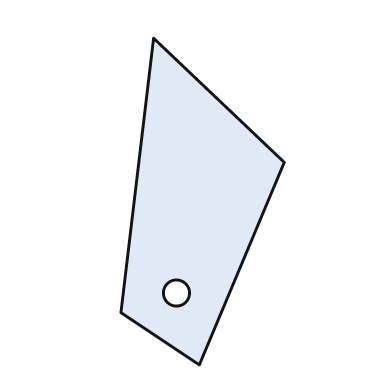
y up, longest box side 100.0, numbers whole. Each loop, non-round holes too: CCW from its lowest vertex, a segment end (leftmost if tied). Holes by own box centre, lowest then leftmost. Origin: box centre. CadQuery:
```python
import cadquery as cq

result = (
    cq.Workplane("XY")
    .moveTo(-1.0, -50.0)
    .lineTo(25.0, 12.0)
    .lineTo(-15.0, 50.0)
    .lineTo(-25.0, -34.0)
    .close()
    .moveTo(-8.0, -28.0)
    .circle(4.0)
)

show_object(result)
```